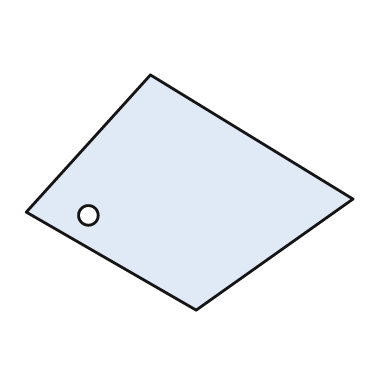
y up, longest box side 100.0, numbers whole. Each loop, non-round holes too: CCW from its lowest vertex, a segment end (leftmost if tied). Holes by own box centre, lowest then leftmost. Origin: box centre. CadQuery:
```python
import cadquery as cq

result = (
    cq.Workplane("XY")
    .moveTo(2.0, -36.0)
    .lineTo(50.0, -2.0)
    .lineTo(-12.0, 36.0)
    .lineTo(-50.0, -6.0)
    .close()
    .moveTo(-31.0, -7.0)
    .circle(3.0)
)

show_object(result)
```